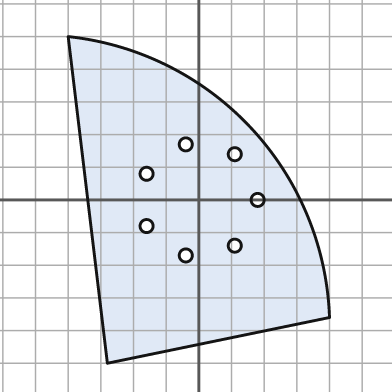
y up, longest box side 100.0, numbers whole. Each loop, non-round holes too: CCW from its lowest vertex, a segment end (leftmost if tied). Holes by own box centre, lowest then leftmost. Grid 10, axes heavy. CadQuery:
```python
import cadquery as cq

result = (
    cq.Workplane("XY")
    .moveTo(-28.0, -50.0)
    .lineTo(40.0, -36.0)
    .threePointArc((16.0, 22.0), (-40.0, 50.0))
    .close()
    .moveTo(-4.0, -17.0)
    .circle(2.0)
    .moveTo(11.0, -14.0)
    .circle(2.0)
    .moveTo(-16.0, -8.0)
    .circle(2.0)
    .moveTo(18.0, 0.0)
    .circle(2.0)
    .moveTo(-16.0, 8.0)
    .circle(2.0)
    .moveTo(11.0, 14.0)
    .circle(2.0)
    .moveTo(-4.0, 17.0)
    .circle(2.0)
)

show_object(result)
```